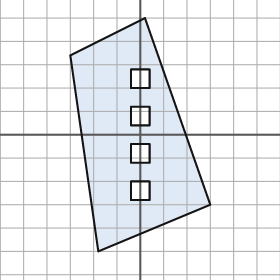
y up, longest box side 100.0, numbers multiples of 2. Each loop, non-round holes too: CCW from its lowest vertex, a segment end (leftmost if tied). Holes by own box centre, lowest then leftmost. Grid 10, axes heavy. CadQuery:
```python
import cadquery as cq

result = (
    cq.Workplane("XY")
    .moveTo(-18.0, -50.0)
    .lineTo(30.0, -30.0)
    .lineTo(2.0, 50.0)
    .lineTo(-30.0, 34.0)
    .close()
    .moveTo(-4.0, -28.0)
    .lineTo(4.0, -28.0)
    .lineTo(4.0, -20.0)
    .lineTo(-4.0, -20.0)
    .close()
    .moveTo(-4.0, -12.0)
    .lineTo(4.0, -12.0)
    .lineTo(4.0, -4.0)
    .lineTo(-4.0, -4.0)
    .close()
    .moveTo(-4.0, 4.0)
    .lineTo(4.0, 4.0)
    .lineTo(4.0, 12.0)
    .lineTo(-4.0, 12.0)
    .close()
    .moveTo(-4.0, 20.0)
    .lineTo(4.0, 20.0)
    .lineTo(4.0, 28.0)
    .lineTo(-4.0, 28.0)
    .close()
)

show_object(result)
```